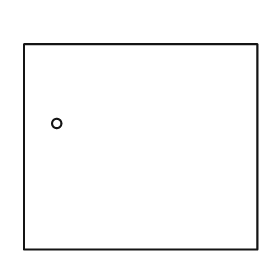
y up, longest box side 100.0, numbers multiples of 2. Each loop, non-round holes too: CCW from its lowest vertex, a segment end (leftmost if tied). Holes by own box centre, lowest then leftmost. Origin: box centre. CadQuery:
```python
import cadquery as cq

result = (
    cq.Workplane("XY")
    .moveTo(-50.0, -44.0)
    .lineTo(50.0, -44.0)
    .lineTo(50.0, 44.0)
    .lineTo(-50.0, 44.0)
    .close()
    .moveTo(-36.0, 10.0)
    .circle(2.0)
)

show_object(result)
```